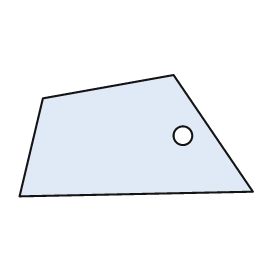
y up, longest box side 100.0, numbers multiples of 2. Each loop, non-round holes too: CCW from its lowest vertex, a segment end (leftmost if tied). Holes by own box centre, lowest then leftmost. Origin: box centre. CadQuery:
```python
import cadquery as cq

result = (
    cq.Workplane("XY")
    .moveTo(-50.0, -26.0)
    .lineTo(50.0, -24.0)
    .lineTo(16.0, 26.0)
    .lineTo(-40.0, 16.0)
    .close()
    .moveTo(20.0, 0.0)
    .circle(4.0)
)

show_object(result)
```